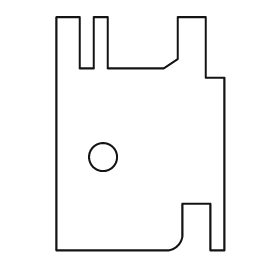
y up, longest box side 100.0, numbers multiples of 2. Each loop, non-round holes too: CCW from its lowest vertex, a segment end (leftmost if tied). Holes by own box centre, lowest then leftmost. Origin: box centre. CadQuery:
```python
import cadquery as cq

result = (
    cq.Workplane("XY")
    .moveTo(-36.0, -50.0)
    .lineTo(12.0, -50.0)
    .threePointArc((16.0, -48.0), (18.0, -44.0))
    .lineTo(18.0, -30.0)
    .lineTo(30.0, -30.0)
    .lineTo(30.0, -50.0)
    .lineTo(36.0, -50.0)
    .lineTo(36.0, 24.0)
    .lineTo(28.0, 24.0)
    .lineTo(28.0, 50.0)
    .lineTo(16.0, 50.0)
    .lineTo(16.0, 32.0)
    .lineTo(10.0, 28.0)
    .lineTo(-14.0, 28.0)
    .lineTo(-14.0, 50.0)
    .lineTo(-20.0, 50.0)
    .lineTo(-20.0, 28.0)
    .lineTo(-26.0, 28.0)
    .lineTo(-26.0, 50.0)
    .lineTo(-36.0, 50.0)
    .close()
    .moveTo(-16.0, -10.0)
    .circle(6.0)
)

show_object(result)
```